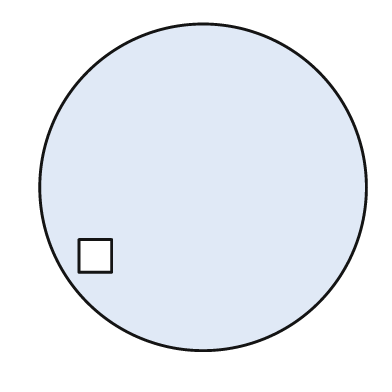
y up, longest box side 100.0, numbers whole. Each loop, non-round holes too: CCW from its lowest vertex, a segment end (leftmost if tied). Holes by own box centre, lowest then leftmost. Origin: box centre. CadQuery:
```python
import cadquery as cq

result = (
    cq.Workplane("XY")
    .moveTo(0.0, 0.0)
    .circle(50.0)
    .moveTo(-38.0, -26.0)
    .lineTo(-28.0, -26.0)
    .lineTo(-28.0, -16.0)
    .lineTo(-38.0, -16.0)
    .close()
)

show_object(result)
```